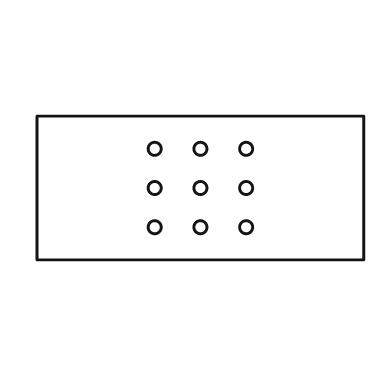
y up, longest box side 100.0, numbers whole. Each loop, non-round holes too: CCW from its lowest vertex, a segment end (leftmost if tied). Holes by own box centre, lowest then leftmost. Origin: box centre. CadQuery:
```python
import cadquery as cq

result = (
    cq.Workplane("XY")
    .moveTo(-50.0, -22.0)
    .lineTo(50.0, -22.0)
    .lineTo(50.0, 22.0)
    .lineTo(-50.0, 22.0)
    .close()
    .moveTo(-14.0, -12.0)
    .circle(2.0)
    .moveTo(0.0, -12.0)
    .circle(2.0)
    .moveTo(14.0, -12.0)
    .circle(2.0)
    .moveTo(-14.0, 0.0)
    .circle(2.0)
    .moveTo(0.0, 0.0)
    .circle(2.0)
    .moveTo(14.0, 0.0)
    .circle(2.0)
    .moveTo(-14.0, 12.0)
    .circle(2.0)
    .moveTo(0.0, 12.0)
    .circle(2.0)
    .moveTo(14.0, 12.0)
    .circle(2.0)
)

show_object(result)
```